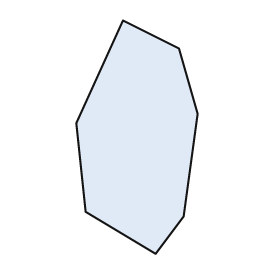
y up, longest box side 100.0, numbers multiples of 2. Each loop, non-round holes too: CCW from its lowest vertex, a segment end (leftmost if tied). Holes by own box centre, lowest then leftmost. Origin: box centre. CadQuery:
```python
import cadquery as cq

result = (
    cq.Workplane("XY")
    .moveTo(8.0, -50.0)
    .lineTo(20.0, -34.0)
    .lineTo(26.0, 10.0)
    .lineTo(18.0, 38.0)
    .lineTo(-6.0, 50.0)
    .lineTo(-26.0, 6.0)
    .lineTo(-22.0, -32.0)
    .close()
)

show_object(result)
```